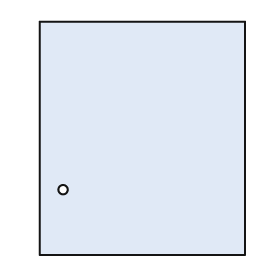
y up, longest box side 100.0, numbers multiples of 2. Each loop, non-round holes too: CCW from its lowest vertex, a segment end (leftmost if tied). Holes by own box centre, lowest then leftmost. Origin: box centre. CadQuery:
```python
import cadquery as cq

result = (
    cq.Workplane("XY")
    .moveTo(-44.0, -50.0)
    .lineTo(44.0, -50.0)
    .lineTo(44.0, 50.0)
    .lineTo(-44.0, 50.0)
    .close()
    .moveTo(-34.0, -22.0)
    .circle(2.0)
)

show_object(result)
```